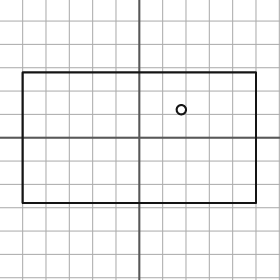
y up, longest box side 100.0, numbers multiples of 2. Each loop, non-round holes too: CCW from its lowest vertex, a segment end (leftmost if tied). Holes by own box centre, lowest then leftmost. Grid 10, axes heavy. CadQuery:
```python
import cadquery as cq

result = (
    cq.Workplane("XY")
    .moveTo(-50.0, -28.0)
    .lineTo(50.0, -28.0)
    .lineTo(50.0, 28.0)
    .lineTo(-50.0, 28.0)
    .close()
    .moveTo(18.0, 12.0)
    .circle(2.0)
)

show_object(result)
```